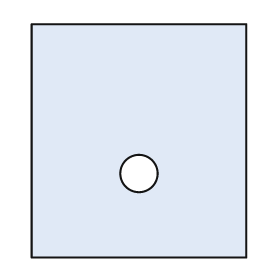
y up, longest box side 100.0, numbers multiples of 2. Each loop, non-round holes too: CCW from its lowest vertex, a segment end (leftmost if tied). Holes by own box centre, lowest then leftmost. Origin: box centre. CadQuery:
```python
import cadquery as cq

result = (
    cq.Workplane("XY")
    .moveTo(-46.0, -50.0)
    .lineTo(46.0, -50.0)
    .lineTo(46.0, 50.0)
    .lineTo(-46.0, 50.0)
    .close()
    .moveTo(0.0, -14.0)
    .circle(8.0)
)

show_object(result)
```